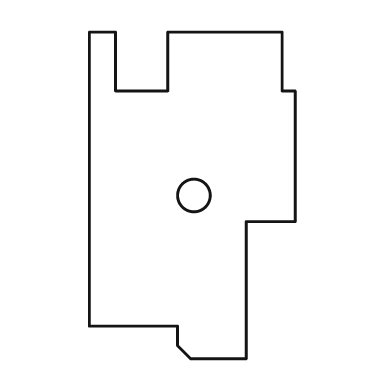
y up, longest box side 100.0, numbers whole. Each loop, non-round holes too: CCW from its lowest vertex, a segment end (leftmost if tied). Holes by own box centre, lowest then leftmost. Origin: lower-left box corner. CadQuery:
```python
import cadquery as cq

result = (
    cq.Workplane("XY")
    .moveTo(31.0, 0.0)
    .lineTo(48.0, 0.0)
    .lineTo(48.0, 42.0)
    .lineTo(63.0, 42.0)
    .lineTo(63.0, 82.0)
    .lineTo(59.0, 82.0)
    .lineTo(59.0, 100.0)
    .lineTo(24.0, 100.0)
    .lineTo(24.0, 82.0)
    .lineTo(8.0, 82.0)
    .lineTo(8.0, 100.0)
    .lineTo(0.0, 100.0)
    .lineTo(0.0, 10.0)
    .lineTo(27.0, 10.0)
    .lineTo(27.0, 4.0)
    .close()
    .moveTo(32.0, 50.0)
    .circle(5.0)
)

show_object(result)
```